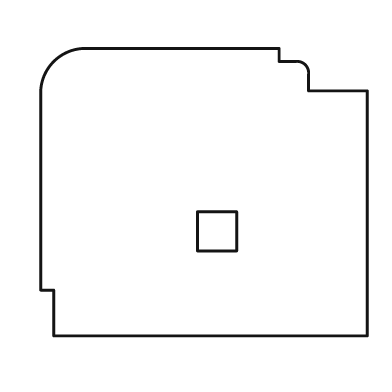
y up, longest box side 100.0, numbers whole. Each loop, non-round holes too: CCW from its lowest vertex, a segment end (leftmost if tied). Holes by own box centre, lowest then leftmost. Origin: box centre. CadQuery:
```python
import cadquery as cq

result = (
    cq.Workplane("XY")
    .moveTo(-46.0, -44.0)
    .lineTo(50.0, -44.0)
    .lineTo(50.0, 31.0)
    .lineTo(32.0, 31.0)
    .lineTo(32.0, 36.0)
    .threePointArc((31.0, 39.0), (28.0, 40.0))
    .lineTo(23.0, 40.0)
    .lineTo(23.0, 44.0)
    .lineTo(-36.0, 44.0)
    .threePointArc((-46.0, 40.0), (-50.0, 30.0))
    .lineTo(-50.0, -30.0)
    .lineTo(-46.0, -30.0)
    .close()
    .moveTo(-2.0, -18.0)
    .lineTo(10.0, -18.0)
    .lineTo(10.0, -6.0)
    .lineTo(-2.0, -6.0)
    .close()
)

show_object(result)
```